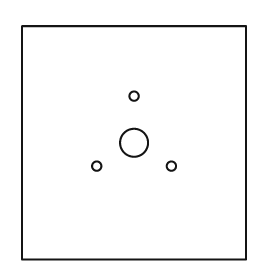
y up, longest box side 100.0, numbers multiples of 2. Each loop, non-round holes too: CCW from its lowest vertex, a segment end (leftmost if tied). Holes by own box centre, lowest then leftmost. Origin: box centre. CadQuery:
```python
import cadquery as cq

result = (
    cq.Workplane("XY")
    .moveTo(-48.0, -50.0)
    .lineTo(48.0, -50.0)
    .lineTo(48.0, 50.0)
    .lineTo(-48.0, 50.0)
    .close()
    .moveTo(-16.0, -10.0)
    .circle(2.0)
    .moveTo(16.0, -10.0)
    .circle(2.0)
    .moveTo(0.0, 0.0)
    .circle(6.0)
    .moveTo(0.0, 20.0)
    .circle(2.0)
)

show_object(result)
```